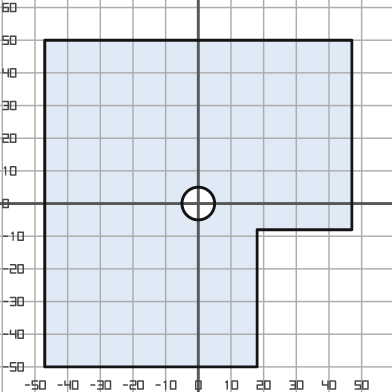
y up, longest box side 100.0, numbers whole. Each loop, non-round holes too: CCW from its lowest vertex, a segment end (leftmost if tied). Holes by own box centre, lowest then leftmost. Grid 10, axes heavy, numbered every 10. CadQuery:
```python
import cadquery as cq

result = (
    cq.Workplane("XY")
    .moveTo(-47.0, -50.0)
    .lineTo(18.0, -50.0)
    .lineTo(18.0, -8.0)
    .lineTo(47.0, -8.0)
    .lineTo(47.0, 50.0)
    .lineTo(-47.0, 50.0)
    .close()
    .moveTo(0.0, 0.0)
    .circle(5.0)
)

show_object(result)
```